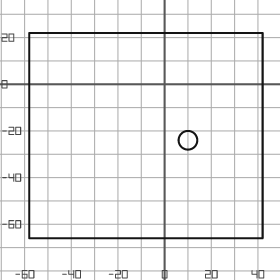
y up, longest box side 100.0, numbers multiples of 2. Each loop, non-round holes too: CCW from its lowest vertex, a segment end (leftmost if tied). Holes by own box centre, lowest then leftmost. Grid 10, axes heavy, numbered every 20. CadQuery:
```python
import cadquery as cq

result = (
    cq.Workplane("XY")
    .moveTo(-58.0, -66.0)
    .lineTo(42.0, -66.0)
    .lineTo(42.0, 22.0)
    .lineTo(-58.0, 22.0)
    .close()
    .moveTo(10.0, -24.0)
    .circle(4.0)
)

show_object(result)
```